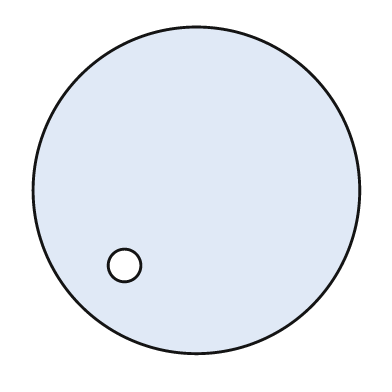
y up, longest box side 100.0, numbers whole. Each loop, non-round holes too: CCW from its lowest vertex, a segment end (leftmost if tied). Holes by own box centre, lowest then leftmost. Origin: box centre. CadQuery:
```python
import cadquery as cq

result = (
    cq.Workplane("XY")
    .moveTo(0.0, 0.0)
    .circle(50.0)
    .moveTo(-22.0, -23.0)
    .circle(5.0)
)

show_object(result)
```